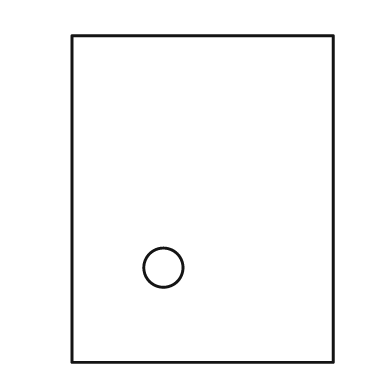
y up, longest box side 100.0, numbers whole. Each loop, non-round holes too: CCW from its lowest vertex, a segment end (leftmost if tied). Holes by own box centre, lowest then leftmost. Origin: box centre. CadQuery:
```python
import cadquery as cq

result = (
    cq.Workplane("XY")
    .moveTo(-40.0, -50.0)
    .lineTo(40.0, -50.0)
    .lineTo(40.0, 50.0)
    .lineTo(-40.0, 50.0)
    .close()
    .moveTo(-12.0, -21.0)
    .circle(6.0)
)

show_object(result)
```